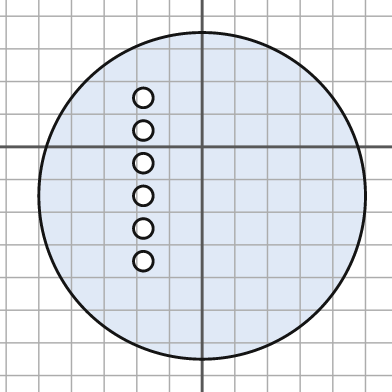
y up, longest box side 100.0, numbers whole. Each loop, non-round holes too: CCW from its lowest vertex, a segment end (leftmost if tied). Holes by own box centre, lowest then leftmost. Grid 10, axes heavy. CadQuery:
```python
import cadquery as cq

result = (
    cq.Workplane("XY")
    .moveTo(0.0, -15.0)
    .circle(50.0)
    .moveTo(-18.0, -35.0)
    .circle(3.0)
    .moveTo(-18.0, -25.0)
    .circle(3.0)
    .moveTo(-18.0, -15.0)
    .circle(3.0)
    .moveTo(-18.0, -5.0)
    .circle(3.0)
    .moveTo(-18.0, 5.0)
    .circle(3.0)
    .moveTo(-18.0, 15.0)
    .circle(3.0)
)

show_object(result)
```